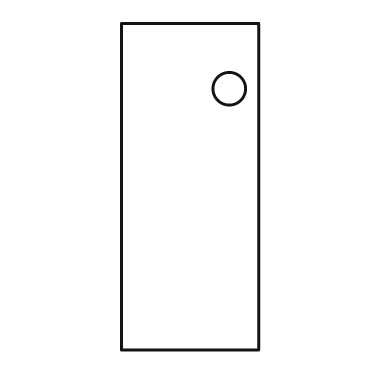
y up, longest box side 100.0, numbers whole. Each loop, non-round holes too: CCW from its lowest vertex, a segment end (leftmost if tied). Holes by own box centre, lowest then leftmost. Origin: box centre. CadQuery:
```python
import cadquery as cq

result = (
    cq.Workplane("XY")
    .moveTo(-21.0, -50.0)
    .lineTo(21.0, -50.0)
    .lineTo(21.0, 50.0)
    .lineTo(-21.0, 50.0)
    .close()
    .moveTo(12.0, 30.0)
    .circle(5.0)
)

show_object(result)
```